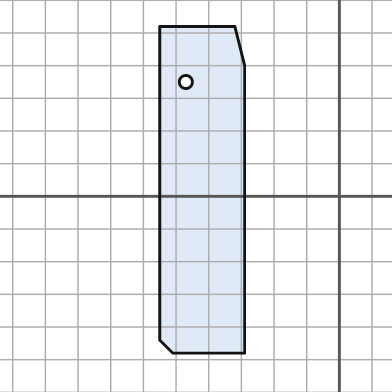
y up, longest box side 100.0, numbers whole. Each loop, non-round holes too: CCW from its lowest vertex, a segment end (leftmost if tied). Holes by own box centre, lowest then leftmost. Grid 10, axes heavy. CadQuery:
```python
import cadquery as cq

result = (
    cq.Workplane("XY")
    .moveTo(-51.0, -48.0)
    .lineTo(-29.0, -48.0)
    .lineTo(-29.0, 40.0)
    .lineTo(-32.0, 52.0)
    .lineTo(-55.0, 52.0)
    .lineTo(-55.0, -44.0)
    .close()
    .moveTo(-47.0, 35.0)
    .circle(2.0)
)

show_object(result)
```